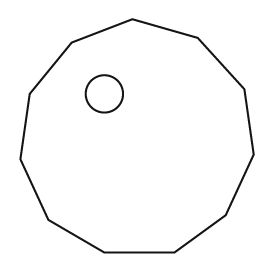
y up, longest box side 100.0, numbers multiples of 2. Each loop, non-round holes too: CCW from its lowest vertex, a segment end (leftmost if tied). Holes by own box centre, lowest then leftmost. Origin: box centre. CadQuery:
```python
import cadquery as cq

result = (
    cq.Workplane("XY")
    .moveTo(-14.0, -50.0)
    .lineTo(16.0, -50.0)
    .lineTo(38.0, -34.0)
    .lineTo(50.0, -8.0)
    .lineTo(46.0, 20.0)
    .lineTo(26.0, 42.0)
    .lineTo(-2.0, 50.0)
    .lineTo(-28.0, 40.0)
    .lineTo(-46.0, 18.0)
    .lineTo(-50.0, -10.0)
    .lineTo(-38.0, -36.0)
    .close()
    .moveTo(-14.0, 18.0)
    .circle(8.0)
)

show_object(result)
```